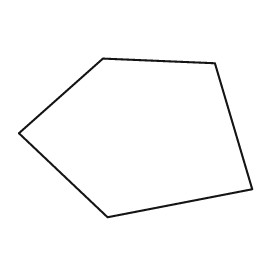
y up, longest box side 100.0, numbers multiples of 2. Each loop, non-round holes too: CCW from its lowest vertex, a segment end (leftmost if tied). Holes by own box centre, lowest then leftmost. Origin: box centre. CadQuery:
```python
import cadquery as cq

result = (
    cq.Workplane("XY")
    .moveTo(-12.0, -34.0)
    .lineTo(50.0, -22.0)
    .lineTo(34.0, 32.0)
    .lineTo(-14.0, 34.0)
    .lineTo(-50.0, 2.0)
    .close()
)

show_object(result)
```